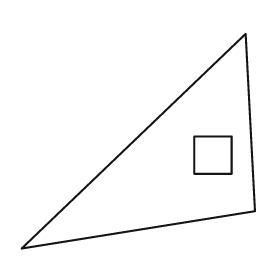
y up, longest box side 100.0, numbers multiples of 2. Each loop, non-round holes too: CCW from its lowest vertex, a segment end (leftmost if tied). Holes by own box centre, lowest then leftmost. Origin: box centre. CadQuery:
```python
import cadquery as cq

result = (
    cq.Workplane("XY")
    .moveTo(-50.0, -46.0)
    .lineTo(50.0, -30.0)
    .lineTo(46.0, 46.0)
    .close()
    .moveTo(24.0, -14.0)
    .lineTo(40.0, -14.0)
    .lineTo(40.0, 2.0)
    .lineTo(24.0, 2.0)
    .close()
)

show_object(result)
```